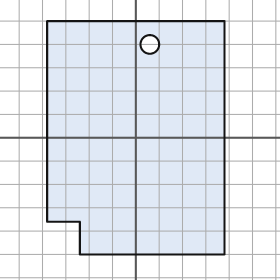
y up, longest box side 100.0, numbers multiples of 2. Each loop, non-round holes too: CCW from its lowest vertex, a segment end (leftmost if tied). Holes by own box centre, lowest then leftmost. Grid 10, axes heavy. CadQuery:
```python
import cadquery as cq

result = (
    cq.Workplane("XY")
    .moveTo(-24.0, -50.0)
    .lineTo(38.0, -50.0)
    .lineTo(38.0, 50.0)
    .lineTo(-38.0, 50.0)
    .lineTo(-38.0, -36.0)
    .lineTo(-24.0, -36.0)
    .close()
    .moveTo(6.0, 40.0)
    .circle(4.0)
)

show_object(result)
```